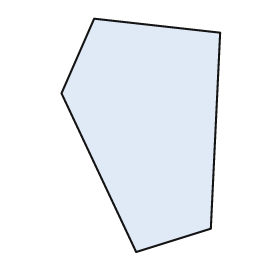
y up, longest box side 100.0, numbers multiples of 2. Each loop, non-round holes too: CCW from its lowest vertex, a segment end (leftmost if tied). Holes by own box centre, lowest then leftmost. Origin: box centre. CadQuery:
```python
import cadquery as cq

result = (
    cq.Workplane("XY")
    .moveTo(-2.0, -50.0)
    .lineTo(30.0, -40.0)
    .lineTo(34.0, 44.0)
    .lineTo(-20.0, 50.0)
    .lineTo(-34.0, 18.0)
    .close()
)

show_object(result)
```